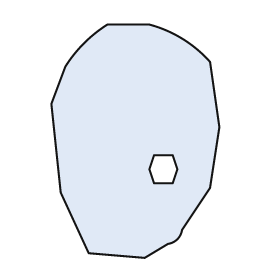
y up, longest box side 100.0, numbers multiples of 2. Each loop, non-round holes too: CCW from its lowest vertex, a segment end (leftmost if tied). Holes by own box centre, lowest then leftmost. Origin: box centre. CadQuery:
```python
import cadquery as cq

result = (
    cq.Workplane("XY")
    .moveTo(4.0, -50.0)
    .lineTo(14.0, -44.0)
    .threePointArc((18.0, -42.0), (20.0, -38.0))
    .lineTo(32.0, -20.0)
    .lineTo(36.0, 6.0)
    .lineTo(32.0, 34.0)
    .threePointArc((20.0, 44.0), (6.0, 50.0))
    .lineTo(-12.0, 50.0)
    .threePointArc((-22.0, 42.0), (-30.0, 32.0))
    .lineTo(-36.0, 16.0)
    .lineTo(-32.0, -22.0)
    .lineTo(-20.0, -48.0)
    .close()
    .moveTo(8.0, -18.0)
    .lineTo(16.0, -18.0)
    .lineTo(18.0, -12.0)
    .lineTo(16.0, -6.0)
    .lineTo(8.0, -6.0)
    .lineTo(6.0, -12.0)
    .close()
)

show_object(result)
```